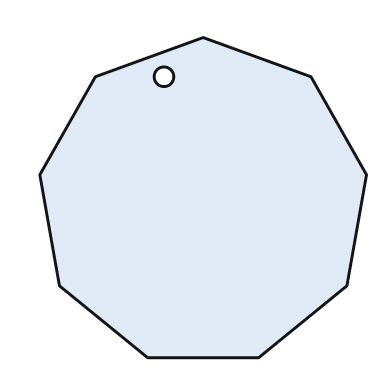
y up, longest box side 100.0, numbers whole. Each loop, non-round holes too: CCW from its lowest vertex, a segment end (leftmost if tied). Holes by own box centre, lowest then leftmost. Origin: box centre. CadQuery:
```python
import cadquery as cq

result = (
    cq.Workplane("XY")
    .moveTo(-17.0, -49.0)
    .lineTo(17.0, -49.0)
    .lineTo(44.0, -27.0)
    .lineTo(50.0, 7.0)
    .lineTo(33.0, 37.0)
    .lineTo(0.0, 49.0)
    .lineTo(-33.0, 37.0)
    .lineTo(-50.0, 7.0)
    .lineTo(-44.0, -27.0)
    .close()
    .moveTo(-12.0, 37.0)
    .circle(3.0)
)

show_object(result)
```